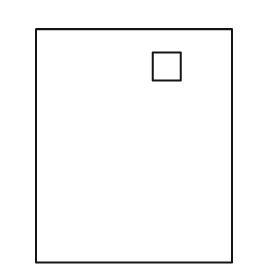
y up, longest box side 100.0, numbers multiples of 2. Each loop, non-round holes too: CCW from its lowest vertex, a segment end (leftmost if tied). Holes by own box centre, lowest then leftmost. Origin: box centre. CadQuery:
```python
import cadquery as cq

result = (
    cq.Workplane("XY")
    .moveTo(-42.0, -50.0)
    .lineTo(42.0, -50.0)
    .lineTo(42.0, 50.0)
    .lineTo(-42.0, 50.0)
    .close()
    .moveTo(8.0, 28.0)
    .lineTo(20.0, 28.0)
    .lineTo(20.0, 40.0)
    .lineTo(8.0, 40.0)
    .close()
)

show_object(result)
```